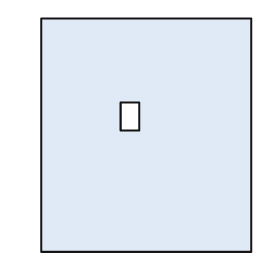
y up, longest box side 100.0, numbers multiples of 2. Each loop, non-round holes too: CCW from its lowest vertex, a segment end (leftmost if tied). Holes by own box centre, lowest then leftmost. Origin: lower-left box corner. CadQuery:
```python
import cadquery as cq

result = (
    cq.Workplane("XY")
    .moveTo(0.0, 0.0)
    .lineTo(90.0, 0.0)
    .lineTo(90.0, 100.0)
    .lineTo(0.0, 100.0)
    .close()
    .moveTo(34.0, 52.0)
    .lineTo(42.0, 52.0)
    .lineTo(42.0, 64.0)
    .lineTo(34.0, 64.0)
    .close()
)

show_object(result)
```